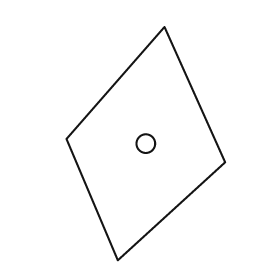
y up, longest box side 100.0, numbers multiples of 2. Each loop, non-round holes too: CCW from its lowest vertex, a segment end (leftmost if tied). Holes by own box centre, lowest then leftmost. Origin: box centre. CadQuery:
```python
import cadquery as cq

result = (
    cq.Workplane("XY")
    .moveTo(-12.0, -50.0)
    .lineTo(34.0, -8.0)
    .lineTo(8.0, 50.0)
    .lineTo(-34.0, 2.0)
    .close()
    .moveTo(0.0, 0.0)
    .circle(4.0)
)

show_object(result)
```